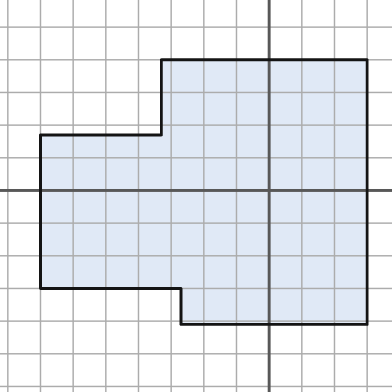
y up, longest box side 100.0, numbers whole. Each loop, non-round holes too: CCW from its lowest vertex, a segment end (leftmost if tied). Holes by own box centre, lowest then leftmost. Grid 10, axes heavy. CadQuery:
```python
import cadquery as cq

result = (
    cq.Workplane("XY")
    .moveTo(-27.0, -41.0)
    .lineTo(30.0, -41.0)
    .lineTo(30.0, 40.0)
    .lineTo(-33.0, 40.0)
    .lineTo(-33.0, 17.0)
    .lineTo(-70.0, 17.0)
    .lineTo(-70.0, -30.0)
    .lineTo(-27.0, -30.0)
    .close()
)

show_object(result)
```